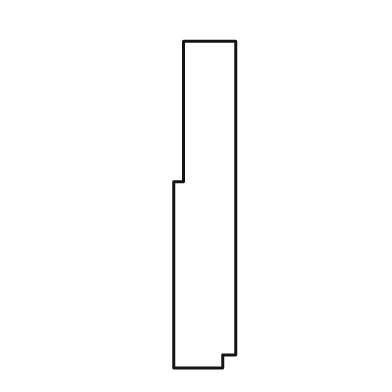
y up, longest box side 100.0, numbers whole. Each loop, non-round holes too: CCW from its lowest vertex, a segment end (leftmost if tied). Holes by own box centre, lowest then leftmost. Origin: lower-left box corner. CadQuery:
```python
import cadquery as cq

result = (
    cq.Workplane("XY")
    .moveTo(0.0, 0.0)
    .lineTo(15.0, 0.0)
    .lineTo(15.0, 4.0)
    .lineTo(19.0, 4.0)
    .lineTo(19.0, 100.0)
    .lineTo(3.0, 100.0)
    .lineTo(3.0, 57.0)
    .lineTo(0.0, 57.0)
    .close()
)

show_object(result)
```